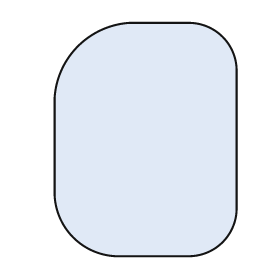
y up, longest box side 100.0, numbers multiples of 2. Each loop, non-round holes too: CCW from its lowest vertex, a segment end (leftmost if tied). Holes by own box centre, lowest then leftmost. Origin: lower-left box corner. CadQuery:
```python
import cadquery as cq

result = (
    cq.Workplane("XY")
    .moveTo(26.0, 0.0)
    .lineTo(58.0, 0.0)
    .threePointArc((72.0, 6.0), (78.0, 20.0))
    .lineTo(78.0, 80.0)
    .threePointArc((72.0, 94.0), (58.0, 100.0))
    .lineTo(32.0, 100.0)
    .threePointArc((10.0, 90.0), (0.0, 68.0))
    .lineTo(0.0, 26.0)
    .threePointArc((8.0, 8.0), (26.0, 0.0))
    .close()
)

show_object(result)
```